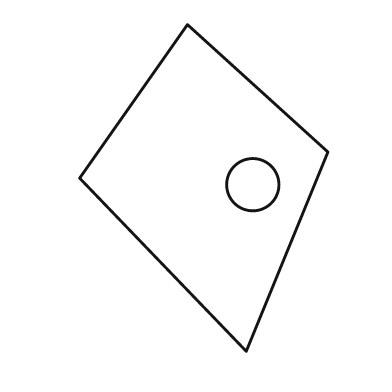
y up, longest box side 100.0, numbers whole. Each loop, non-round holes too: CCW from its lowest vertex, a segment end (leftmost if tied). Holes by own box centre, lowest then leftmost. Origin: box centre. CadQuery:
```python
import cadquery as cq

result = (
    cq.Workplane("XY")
    .moveTo(13.0, -50.0)
    .lineTo(38.0, 11.0)
    .lineTo(-5.0, 50.0)
    .lineTo(-38.0, 3.0)
    .close()
    .moveTo(15.0, 1.0)
    .circle(8.0)
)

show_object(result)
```